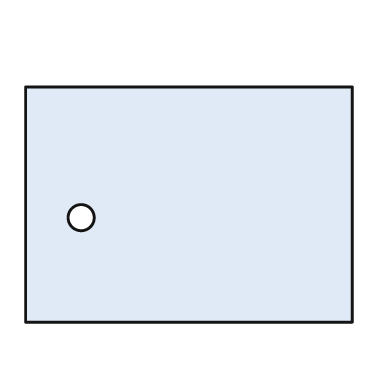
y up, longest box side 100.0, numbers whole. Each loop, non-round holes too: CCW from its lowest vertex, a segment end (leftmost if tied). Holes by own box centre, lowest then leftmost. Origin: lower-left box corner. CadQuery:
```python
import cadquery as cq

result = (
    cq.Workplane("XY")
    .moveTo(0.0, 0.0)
    .lineTo(100.0, 0.0)
    .lineTo(100.0, 72.0)
    .lineTo(0.0, 72.0)
    .close()
    .moveTo(17.0, 32.0)
    .circle(4.0)
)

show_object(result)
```